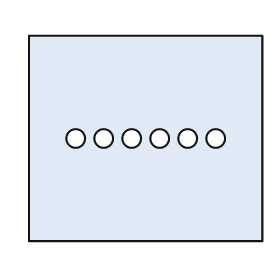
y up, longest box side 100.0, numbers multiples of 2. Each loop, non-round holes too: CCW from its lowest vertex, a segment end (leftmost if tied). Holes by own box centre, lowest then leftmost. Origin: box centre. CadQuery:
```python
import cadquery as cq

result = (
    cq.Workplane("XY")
    .moveTo(-50.0, -44.0)
    .lineTo(50.0, -44.0)
    .lineTo(50.0, 44.0)
    .lineTo(-50.0, 44.0)
    .close()
    .moveTo(-30.0, 0.0)
    .circle(4.0)
    .moveTo(-18.0, 0.0)
    .circle(4.0)
    .moveTo(-6.0, 0.0)
    .circle(4.0)
    .moveTo(6.0, 0.0)
    .circle(4.0)
    .moveTo(18.0, 0.0)
    .circle(4.0)
    .moveTo(30.0, 0.0)
    .circle(4.0)
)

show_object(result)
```